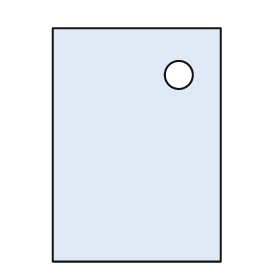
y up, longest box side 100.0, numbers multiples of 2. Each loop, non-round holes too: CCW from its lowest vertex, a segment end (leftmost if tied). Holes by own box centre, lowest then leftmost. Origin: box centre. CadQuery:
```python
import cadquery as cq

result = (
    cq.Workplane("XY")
    .moveTo(-36.0, -50.0)
    .lineTo(36.0, -50.0)
    .lineTo(36.0, 50.0)
    .lineTo(-36.0, 50.0)
    .close()
    .moveTo(18.0, 30.0)
    .circle(6.0)
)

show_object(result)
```